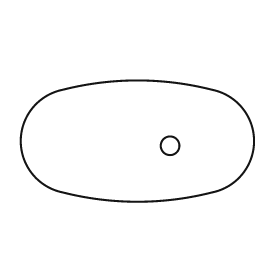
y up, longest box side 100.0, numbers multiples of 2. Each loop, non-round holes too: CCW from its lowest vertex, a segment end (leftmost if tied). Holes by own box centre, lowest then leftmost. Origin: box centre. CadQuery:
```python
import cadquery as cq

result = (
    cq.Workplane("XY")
    .moveTo(-32.0, -22.0)
    .threePointArc((0.0, -26.0), (32.0, -22.0))
    .threePointArc((50.0, 0.0), (32.0, 22.0))
    .threePointArc((0.0, 26.0), (-32.0, 22.0))
    .threePointArc((-50.0, 0.0), (-32.0, -22.0))
    .close()
    .moveTo(14.0, -2.0)
    .circle(4.0)
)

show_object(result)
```